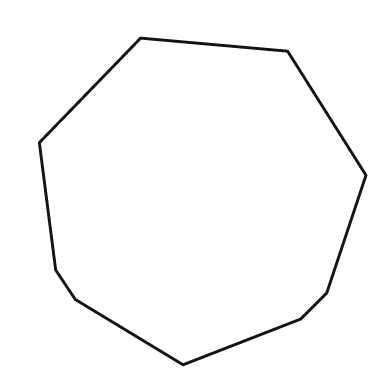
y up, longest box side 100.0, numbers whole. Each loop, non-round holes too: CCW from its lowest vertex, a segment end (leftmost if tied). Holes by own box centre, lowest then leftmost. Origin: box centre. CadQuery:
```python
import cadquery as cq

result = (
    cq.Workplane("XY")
    .moveTo(-6.0, -50.0)
    .lineTo(30.0, -36.0)
    .lineTo(38.0, -28.0)
    .lineTo(50.0, 8.0)
    .lineTo(26.0, 46.0)
    .lineTo(-19.0, 50.0)
    .lineTo(-50.0, 18.0)
    .lineTo(-45.0, -21.0)
    .lineTo(-39.0, -30.0)
    .close()
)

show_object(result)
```